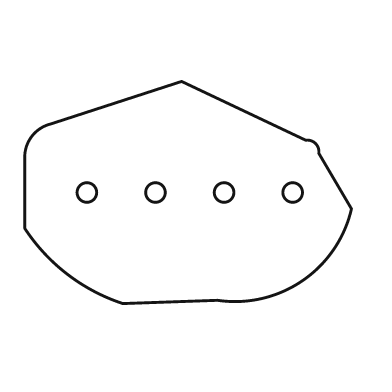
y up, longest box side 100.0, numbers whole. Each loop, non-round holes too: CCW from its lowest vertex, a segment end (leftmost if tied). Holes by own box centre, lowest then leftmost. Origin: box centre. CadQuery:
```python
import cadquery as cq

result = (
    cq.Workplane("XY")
    .moveTo(-20.0, -34.0)
    .lineTo(9.0, -33.0)
    .threePointArc((35.0, -27.0), (50.0, -5.0))
    .lineTo(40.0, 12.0)
    .threePointArc((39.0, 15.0), (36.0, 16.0))
    .lineTo(-2.0, 34.0)
    .lineTo(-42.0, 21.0)
    .threePointArc((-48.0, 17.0), (-50.0, 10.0))
    .lineTo(-50.0, -11.0)
    .threePointArc((-37.0, -25.0), (-20.0, -34.0))
    .close()
    .moveTo(-31.0, 0.0)
    .circle(3.0)
    .moveTo(-10.0, 0.0)
    .circle(3.0)
    .moveTo(11.0, 0.0)
    .circle(3.0)
    .moveTo(32.0, 0.0)
    .circle(3.0)
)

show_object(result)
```